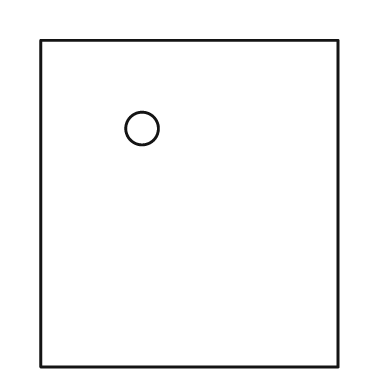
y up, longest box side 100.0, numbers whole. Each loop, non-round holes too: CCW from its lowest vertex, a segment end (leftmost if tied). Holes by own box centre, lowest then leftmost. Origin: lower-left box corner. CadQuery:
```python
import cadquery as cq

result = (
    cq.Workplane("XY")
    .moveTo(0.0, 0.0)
    .lineTo(91.0, 0.0)
    .lineTo(91.0, 100.0)
    .lineTo(0.0, 100.0)
    .close()
    .moveTo(31.0, 73.0)
    .circle(5.0)
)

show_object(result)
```